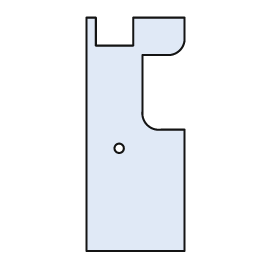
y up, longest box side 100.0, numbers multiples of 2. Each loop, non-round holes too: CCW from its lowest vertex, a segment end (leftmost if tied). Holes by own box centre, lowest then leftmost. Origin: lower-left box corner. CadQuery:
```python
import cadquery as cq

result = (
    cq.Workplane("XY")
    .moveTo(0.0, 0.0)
    .lineTo(42.0, 0.0)
    .lineTo(42.0, 52.0)
    .lineTo(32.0, 52.0)
    .threePointArc((26.0, 54.0), (24.0, 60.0))
    .lineTo(24.0, 84.0)
    .lineTo(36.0, 84.0)
    .threePointArc((40.0, 86.0), (42.0, 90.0))
    .lineTo(42.0, 100.0)
    .lineTo(20.0, 100.0)
    .lineTo(20.0, 88.0)
    .lineTo(4.0, 88.0)
    .lineTo(4.0, 100.0)
    .lineTo(0.0, 100.0)
    .close()
    .moveTo(14.0, 44.0)
    .circle(2.0)
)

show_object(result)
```